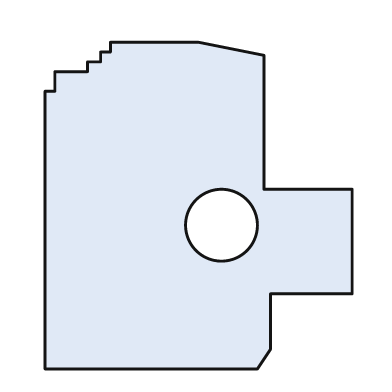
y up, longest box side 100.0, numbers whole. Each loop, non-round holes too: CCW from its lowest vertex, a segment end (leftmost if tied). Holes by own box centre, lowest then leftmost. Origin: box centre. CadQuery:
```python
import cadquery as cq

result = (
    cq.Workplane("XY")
    .moveTo(-47.0, -50.0)
    .lineTo(18.0, -50.0)
    .lineTo(22.0, -44.0)
    .lineTo(22.0, -27.0)
    .lineTo(47.0, -27.0)
    .lineTo(47.0, 5.0)
    .lineTo(20.0, 5.0)
    .lineTo(20.0, 46.0)
    .lineTo(0.0, 50.0)
    .lineTo(-27.0, 50.0)
    .lineTo(-27.0, 47.0)
    .lineTo(-30.0, 47.0)
    .lineTo(-30.0, 44.0)
    .lineTo(-34.0, 44.0)
    .lineTo(-34.0, 41.0)
    .lineTo(-44.0, 41.0)
    .lineTo(-44.0, 35.0)
    .lineTo(-47.0, 35.0)
    .close()
    .moveTo(7.0, -6.0)
    .circle(11.0)
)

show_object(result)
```